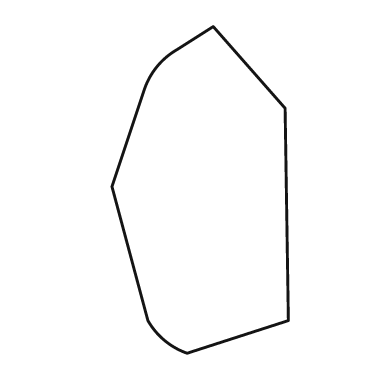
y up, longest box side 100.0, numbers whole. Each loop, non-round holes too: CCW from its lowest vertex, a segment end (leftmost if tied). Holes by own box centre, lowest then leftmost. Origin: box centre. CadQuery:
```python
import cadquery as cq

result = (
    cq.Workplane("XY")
    .moveTo(-4.0, -50.0)
    .lineTo(27.0, -40.0)
    .lineTo(26.0, 25.0)
    .lineTo(4.0, 50.0)
    .lineTo(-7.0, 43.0)
    .threePointArc((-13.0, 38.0), (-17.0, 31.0))
    .lineTo(-27.0, 1.0)
    .lineTo(-16.0, -40.0)
    .threePointArc((-11.0, -46.0), (-4.0, -50.0))
    .close()
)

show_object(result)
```